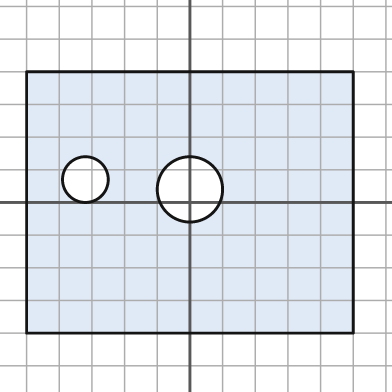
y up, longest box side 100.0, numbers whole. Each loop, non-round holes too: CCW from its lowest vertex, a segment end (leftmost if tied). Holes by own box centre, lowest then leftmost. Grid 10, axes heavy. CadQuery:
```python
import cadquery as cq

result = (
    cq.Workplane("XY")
    .moveTo(-50.0, -40.0)
    .lineTo(50.0, -40.0)
    .lineTo(50.0, 40.0)
    .lineTo(-50.0, 40.0)
    .close()
    .moveTo(0.0, 4.0)
    .circle(10.0)
    .moveTo(-32.0, 7.0)
    .circle(7.0)
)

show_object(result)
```